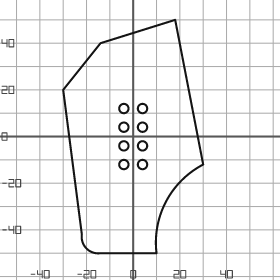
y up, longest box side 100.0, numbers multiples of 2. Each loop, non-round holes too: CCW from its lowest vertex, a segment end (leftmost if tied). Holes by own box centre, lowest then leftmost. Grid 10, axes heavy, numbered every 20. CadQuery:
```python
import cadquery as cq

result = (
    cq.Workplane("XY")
    .moveTo(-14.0, -50.0)
    .lineTo(10.0, -50.0)
    .threePointArc((14.0, -28.0), (30.0, -12.0))
    .lineTo(18.0, 50.0)
    .lineTo(-14.0, 40.0)
    .lineTo(-30.0, 20.0)
    .lineTo(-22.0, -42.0)
    .threePointArc((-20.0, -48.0), (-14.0, -50.0))
    .close()
    .moveTo(-4.0, -12.0)
    .circle(2.0)
    .moveTo(4.0, -12.0)
    .circle(2.0)
    .moveTo(-4.0, -4.0)
    .circle(2.0)
    .moveTo(4.0, -4.0)
    .circle(2.0)
    .moveTo(-4.0, 4.0)
    .circle(2.0)
    .moveTo(4.0, 4.0)
    .circle(2.0)
    .moveTo(-4.0, 12.0)
    .circle(2.0)
    .moveTo(4.0, 12.0)
    .circle(2.0)
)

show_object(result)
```